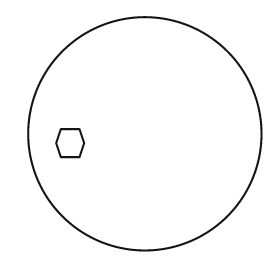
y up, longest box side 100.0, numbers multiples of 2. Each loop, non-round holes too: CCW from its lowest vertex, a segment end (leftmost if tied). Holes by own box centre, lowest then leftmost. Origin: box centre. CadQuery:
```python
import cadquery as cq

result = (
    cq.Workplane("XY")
    .moveTo(0.0, 0.0)
    .circle(50.0)
    .moveTo(-36.0, -10.0)
    .lineTo(-28.0, -10.0)
    .lineTo(-26.0, -4.0)
    .lineTo(-28.0, 2.0)
    .lineTo(-36.0, 2.0)
    .lineTo(-38.0, -4.0)
    .close()
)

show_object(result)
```